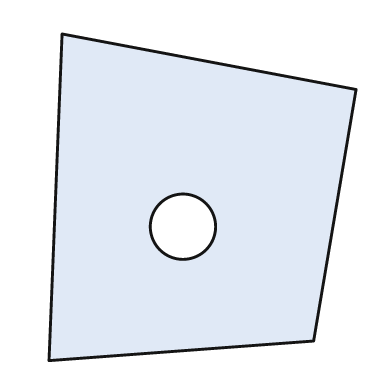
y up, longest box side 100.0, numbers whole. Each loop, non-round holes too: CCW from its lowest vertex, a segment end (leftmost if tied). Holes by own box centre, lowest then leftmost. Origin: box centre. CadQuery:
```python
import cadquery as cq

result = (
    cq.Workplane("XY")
    .moveTo(-47.0, -50.0)
    .lineTo(34.0, -44.0)
    .lineTo(47.0, 33.0)
    .lineTo(-43.0, 50.0)
    .close()
    .moveTo(-6.0, -9.0)
    .circle(10.0)
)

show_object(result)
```